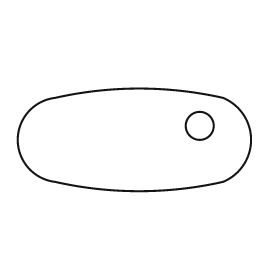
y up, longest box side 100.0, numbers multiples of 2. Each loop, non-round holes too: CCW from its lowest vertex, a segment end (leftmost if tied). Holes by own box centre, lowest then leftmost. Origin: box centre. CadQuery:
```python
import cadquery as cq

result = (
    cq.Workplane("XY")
    .moveTo(-34.0, -18.0)
    .threePointArc((2.0, -22.0), (38.0, -18.0))
    .threePointArc((50.0, 0.0), (38.0, 18.0))
    .threePointArc((2.0, 22.0), (-34.0, 18.0))
    .threePointArc((-50.0, 0.0), (-34.0, -18.0))
    .close()
    .moveTo(28.0, 6.0)
    .circle(6.0)
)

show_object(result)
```